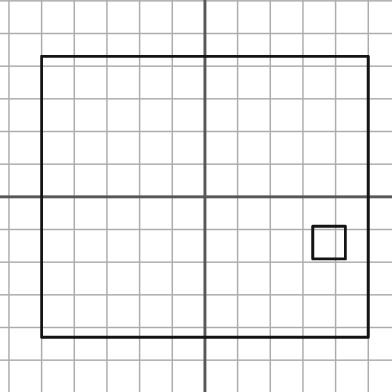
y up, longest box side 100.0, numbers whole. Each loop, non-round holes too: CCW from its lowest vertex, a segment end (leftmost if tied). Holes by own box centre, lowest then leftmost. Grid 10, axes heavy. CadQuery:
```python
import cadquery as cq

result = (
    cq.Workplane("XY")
    .moveTo(-50.0, -43.0)
    .lineTo(50.0, -43.0)
    .lineTo(50.0, 43.0)
    .lineTo(-50.0, 43.0)
    .close()
    .moveTo(33.0, -19.0)
    .lineTo(43.0, -19.0)
    .lineTo(43.0, -9.0)
    .lineTo(33.0, -9.0)
    .close()
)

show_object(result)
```